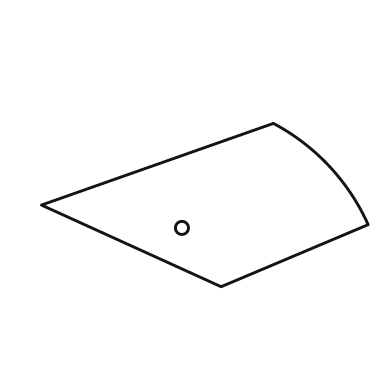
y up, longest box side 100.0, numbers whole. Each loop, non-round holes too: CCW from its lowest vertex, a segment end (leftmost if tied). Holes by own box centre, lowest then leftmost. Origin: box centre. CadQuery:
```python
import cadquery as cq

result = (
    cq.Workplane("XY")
    .moveTo(5.0, -25.0)
    .lineTo(50.0, -6.0)
    .threePointArc((38.0, 12.0), (21.0, 25.0))
    .lineTo(-50.0, 0.0)
    .close()
    .moveTo(-7.0, -7.0)
    .circle(2.0)
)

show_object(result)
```